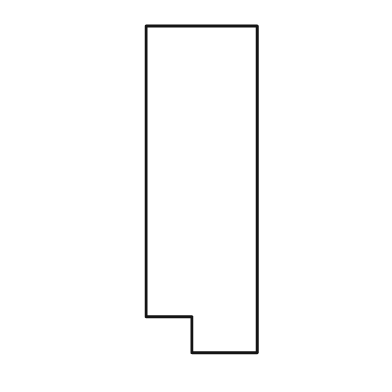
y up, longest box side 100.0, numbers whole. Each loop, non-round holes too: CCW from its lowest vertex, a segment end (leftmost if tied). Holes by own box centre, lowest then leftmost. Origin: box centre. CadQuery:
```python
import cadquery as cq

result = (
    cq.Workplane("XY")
    .moveTo(-3.0, -50.0)
    .lineTo(17.0, -50.0)
    .lineTo(17.0, 50.0)
    .lineTo(-17.0, 50.0)
    .lineTo(-17.0, -39.0)
    .lineTo(-3.0, -39.0)
    .close()
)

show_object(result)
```